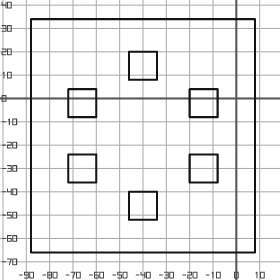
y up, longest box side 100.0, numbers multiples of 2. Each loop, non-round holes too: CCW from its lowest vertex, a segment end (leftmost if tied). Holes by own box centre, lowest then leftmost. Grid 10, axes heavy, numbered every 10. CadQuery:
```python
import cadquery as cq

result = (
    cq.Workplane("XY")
    .moveTo(-88.0, -66.0)
    .lineTo(8.0, -66.0)
    .lineTo(8.0, 34.0)
    .lineTo(-88.0, 34.0)
    .close()
    .moveTo(-46.0, -52.0)
    .lineTo(-34.0, -52.0)
    .lineTo(-34.0, -40.0)
    .lineTo(-46.0, -40.0)
    .close()
    .moveTo(-72.0, -36.0)
    .lineTo(-60.0, -36.0)
    .lineTo(-60.0, -24.0)
    .lineTo(-72.0, -24.0)
    .close()
    .moveTo(-20.0, -36.0)
    .lineTo(-8.0, -36.0)
    .lineTo(-8.0, -24.0)
    .lineTo(-20.0, -24.0)
    .close()
    .moveTo(-72.0, -8.0)
    .lineTo(-60.0, -8.0)
    .lineTo(-60.0, 4.0)
    .lineTo(-72.0, 4.0)
    .close()
    .moveTo(-20.0, -8.0)
    .lineTo(-8.0, -8.0)
    .lineTo(-8.0, 4.0)
    .lineTo(-20.0, 4.0)
    .close()
    .moveTo(-46.0, 8.0)
    .lineTo(-34.0, 8.0)
    .lineTo(-34.0, 20.0)
    .lineTo(-46.0, 20.0)
    .close()
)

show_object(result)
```